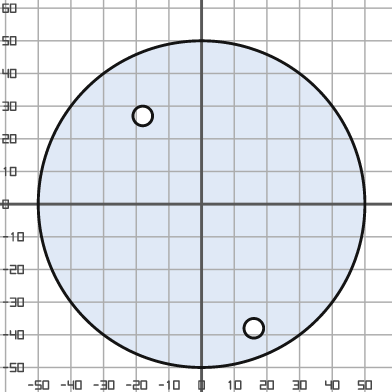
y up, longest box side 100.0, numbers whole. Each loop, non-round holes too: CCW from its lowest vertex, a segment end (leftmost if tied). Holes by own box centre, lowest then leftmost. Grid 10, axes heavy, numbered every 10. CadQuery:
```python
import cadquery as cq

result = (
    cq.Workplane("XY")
    .moveTo(0.0, 0.0)
    .circle(50.0)
    .moveTo(16.0, -38.0)
    .circle(3.0)
    .moveTo(-18.0, 27.0)
    .circle(3.0)
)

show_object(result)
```